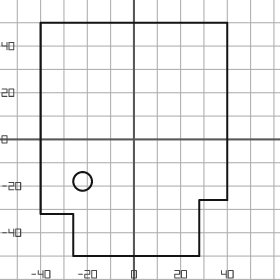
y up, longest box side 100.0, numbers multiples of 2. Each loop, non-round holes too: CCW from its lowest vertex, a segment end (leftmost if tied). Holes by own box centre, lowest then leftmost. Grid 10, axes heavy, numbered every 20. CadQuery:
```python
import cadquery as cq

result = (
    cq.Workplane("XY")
    .moveTo(-26.0, -50.0)
    .lineTo(28.0, -50.0)
    .lineTo(28.0, -26.0)
    .lineTo(40.0, -26.0)
    .lineTo(40.0, 50.0)
    .lineTo(-40.0, 50.0)
    .lineTo(-40.0, -32.0)
    .lineTo(-26.0, -32.0)
    .close()
    .moveTo(-22.0, -18.0)
    .circle(4.0)
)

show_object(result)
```